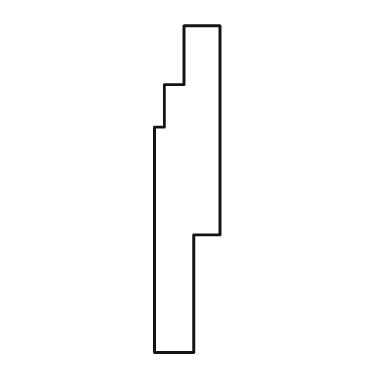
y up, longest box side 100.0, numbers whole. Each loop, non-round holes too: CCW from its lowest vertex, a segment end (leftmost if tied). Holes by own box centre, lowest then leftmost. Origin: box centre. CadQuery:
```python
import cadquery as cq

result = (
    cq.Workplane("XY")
    .moveTo(-10.0, -50.0)
    .lineTo(2.0, -50.0)
    .lineTo(2.0, -14.0)
    .lineTo(10.0, -14.0)
    .lineTo(10.0, 50.0)
    .lineTo(-1.0, 50.0)
    .lineTo(-1.0, 32.0)
    .lineTo(-7.0, 32.0)
    .lineTo(-7.0, 19.0)
    .lineTo(-10.0, 19.0)
    .close()
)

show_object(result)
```